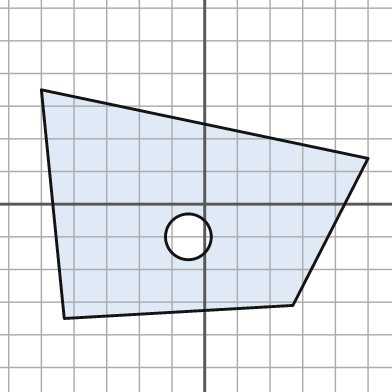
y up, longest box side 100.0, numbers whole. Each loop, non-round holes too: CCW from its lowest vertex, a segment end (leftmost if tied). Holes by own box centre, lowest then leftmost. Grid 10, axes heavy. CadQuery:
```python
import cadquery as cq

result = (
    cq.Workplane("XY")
    .moveTo(-43.0, -35.0)
    .lineTo(27.0, -31.0)
    .lineTo(50.0, 14.0)
    .lineTo(-50.0, 35.0)
    .close()
    .moveTo(-5.0, -10.0)
    .circle(7.0)
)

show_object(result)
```